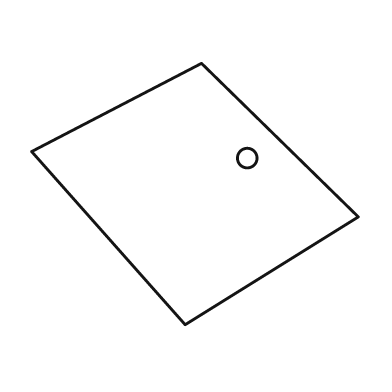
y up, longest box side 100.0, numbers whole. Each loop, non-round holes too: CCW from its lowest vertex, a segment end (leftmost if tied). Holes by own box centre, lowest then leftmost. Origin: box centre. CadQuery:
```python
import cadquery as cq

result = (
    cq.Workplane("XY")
    .moveTo(-3.0, -40.0)
    .lineTo(50.0, -7.0)
    .lineTo(2.0, 40.0)
    .lineTo(-50.0, 13.0)
    .close()
    .moveTo(16.0, 11.0)
    .circle(3.0)
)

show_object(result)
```